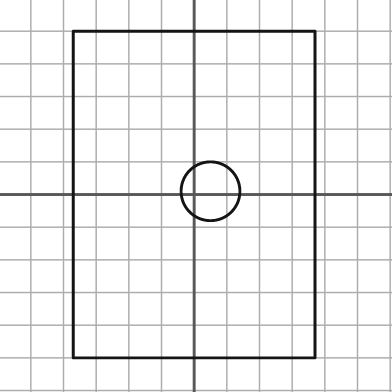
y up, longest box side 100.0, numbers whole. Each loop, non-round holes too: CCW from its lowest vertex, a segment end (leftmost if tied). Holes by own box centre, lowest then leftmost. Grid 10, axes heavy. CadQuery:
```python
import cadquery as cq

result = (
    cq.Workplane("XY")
    .moveTo(-37.0, -50.0)
    .lineTo(37.0, -50.0)
    .lineTo(37.0, 50.0)
    .lineTo(-37.0, 50.0)
    .close()
    .moveTo(5.0, 1.0)
    .circle(9.0)
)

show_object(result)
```